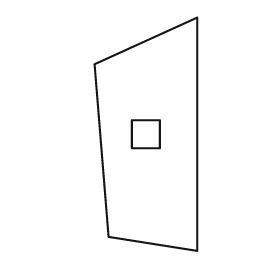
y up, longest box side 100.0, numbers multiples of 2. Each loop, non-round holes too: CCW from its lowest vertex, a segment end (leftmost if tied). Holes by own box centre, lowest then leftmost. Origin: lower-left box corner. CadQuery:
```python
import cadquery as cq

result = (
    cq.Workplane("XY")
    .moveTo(44.0, 0.0)
    .lineTo(44.0, 100.0)
    .lineTo(0.0, 80.0)
    .lineTo(6.0, 6.0)
    .close()
    .moveTo(16.0, 44.0)
    .lineTo(28.0, 44.0)
    .lineTo(28.0, 56.0)
    .lineTo(16.0, 56.0)
    .close()
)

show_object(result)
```